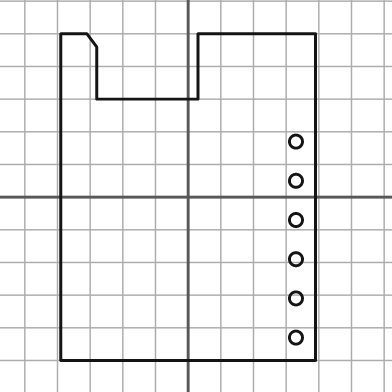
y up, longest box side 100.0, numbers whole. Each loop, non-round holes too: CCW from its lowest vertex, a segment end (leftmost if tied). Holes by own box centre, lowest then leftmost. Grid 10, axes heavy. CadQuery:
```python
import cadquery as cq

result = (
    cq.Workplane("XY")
    .moveTo(-39.0, -50.0)
    .lineTo(39.0, -50.0)
    .lineTo(39.0, 50.0)
    .lineTo(3.0, 50.0)
    .lineTo(3.0, 30.0)
    .lineTo(-28.0, 30.0)
    .lineTo(-28.0, 46.0)
    .lineTo(-31.0, 50.0)
    .lineTo(-39.0, 50.0)
    .close()
    .moveTo(33.0, -43.0)
    .circle(2.0)
    .moveTo(33.0, -31.0)
    .circle(2.0)
    .moveTo(33.0, -19.0)
    .circle(2.0)
    .moveTo(33.0, -7.0)
    .circle(2.0)
    .moveTo(33.0, 5.0)
    .circle(2.0)
    .moveTo(33.0, 17.0)
    .circle(2.0)
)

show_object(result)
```